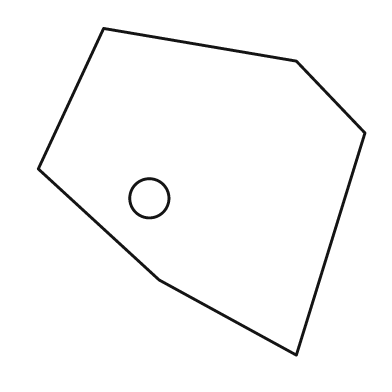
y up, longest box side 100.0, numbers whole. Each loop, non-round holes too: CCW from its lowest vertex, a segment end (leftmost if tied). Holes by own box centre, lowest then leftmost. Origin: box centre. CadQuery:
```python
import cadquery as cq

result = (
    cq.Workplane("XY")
    .moveTo(29.0, -50.0)
    .lineTo(50.0, 18.0)
    .lineTo(29.0, 40.0)
    .lineTo(-30.0, 50.0)
    .lineTo(-50.0, 7.0)
    .lineTo(-13.0, -27.0)
    .close()
    .moveTo(-16.0, -2.0)
    .circle(6.0)
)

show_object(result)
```